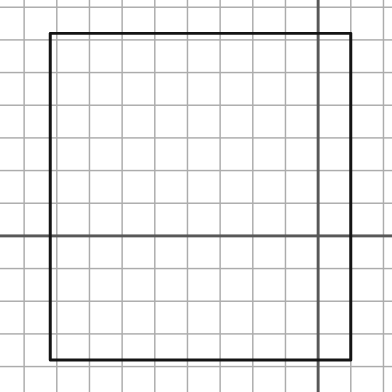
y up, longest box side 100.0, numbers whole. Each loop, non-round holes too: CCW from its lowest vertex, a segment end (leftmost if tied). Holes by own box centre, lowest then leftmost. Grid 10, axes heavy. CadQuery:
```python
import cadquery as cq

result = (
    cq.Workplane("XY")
    .moveTo(-82.0, -38.0)
    .lineTo(10.0, -38.0)
    .lineTo(10.0, 62.0)
    .lineTo(-82.0, 62.0)
    .close()
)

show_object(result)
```